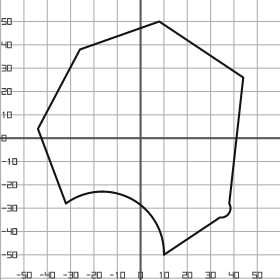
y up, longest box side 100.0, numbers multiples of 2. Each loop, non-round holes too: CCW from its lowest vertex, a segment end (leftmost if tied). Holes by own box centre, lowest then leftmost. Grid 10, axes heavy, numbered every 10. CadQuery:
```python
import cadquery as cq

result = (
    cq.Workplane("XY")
    .moveTo(10.0, -50.0)
    .lineTo(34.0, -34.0)
    .threePointArc((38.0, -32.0), (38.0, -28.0))
    .lineTo(44.0, 26.0)
    .lineTo(8.0, 50.0)
    .lineTo(-26.0, 38.0)
    .lineTo(-44.0, 4.0)
    .lineTo(-32.0, -28.0)
    .threePointArc((-4.0, -26.0), (10.0, -50.0))
    .close()
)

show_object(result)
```